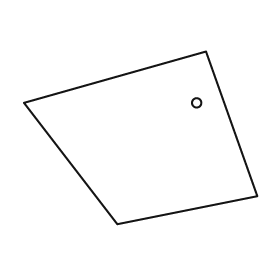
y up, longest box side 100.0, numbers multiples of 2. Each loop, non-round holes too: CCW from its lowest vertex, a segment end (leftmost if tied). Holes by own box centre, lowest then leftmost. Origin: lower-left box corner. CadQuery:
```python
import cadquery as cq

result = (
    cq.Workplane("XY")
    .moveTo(40.0, 0.0)
    .lineTo(100.0, 12.0)
    .lineTo(78.0, 74.0)
    .lineTo(0.0, 52.0)
    .close()
    .moveTo(74.0, 52.0)
    .circle(2.0)
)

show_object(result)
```